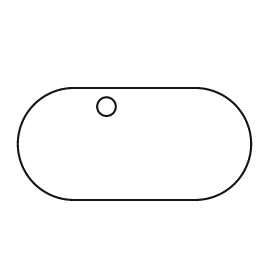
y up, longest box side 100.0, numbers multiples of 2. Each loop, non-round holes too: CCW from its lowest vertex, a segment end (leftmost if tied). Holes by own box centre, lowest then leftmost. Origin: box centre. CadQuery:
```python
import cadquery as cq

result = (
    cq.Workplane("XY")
    .moveTo(-26.0, -24.0)
    .lineTo(26.0, -24.0)
    .threePointArc((50.0, 0.0), (26.0, 24.0))
    .lineTo(-26.0, 24.0)
    .threePointArc((-50.0, 0.0), (-26.0, -24.0))
    .close()
    .moveTo(-12.0, 16.0)
    .circle(4.0)
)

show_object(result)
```